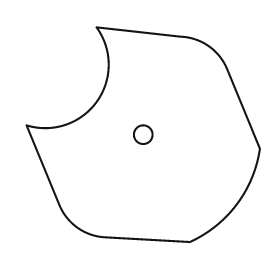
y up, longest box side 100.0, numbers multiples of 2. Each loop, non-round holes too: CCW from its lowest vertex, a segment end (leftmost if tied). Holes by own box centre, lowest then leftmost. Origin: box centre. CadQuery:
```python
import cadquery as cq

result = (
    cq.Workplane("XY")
    .moveTo(20.0, -46.0)
    .threePointArc((40.0, -30.0), (50.0, -6.0))
    .lineTo(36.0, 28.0)
    .threePointArc((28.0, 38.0), (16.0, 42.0))
    .lineTo(-20.0, 46.0)
    .threePointArc((-20.0, 14.0), (-50.0, 4.0))
    .lineTo(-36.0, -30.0)
    .threePointArc((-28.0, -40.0), (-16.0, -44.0))
    .close()
    .moveTo(0.0, 0.0)
    .circle(4.0)
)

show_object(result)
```